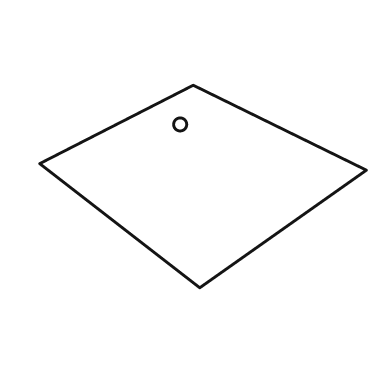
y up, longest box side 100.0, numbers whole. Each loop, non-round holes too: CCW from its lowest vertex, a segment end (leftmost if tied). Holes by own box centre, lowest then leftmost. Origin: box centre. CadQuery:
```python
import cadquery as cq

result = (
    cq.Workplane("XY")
    .moveTo(-1.0, -31.0)
    .lineTo(50.0, 5.0)
    .lineTo(-3.0, 31.0)
    .lineTo(-50.0, 7.0)
    .close()
    .moveTo(-7.0, 19.0)
    .circle(2.0)
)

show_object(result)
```